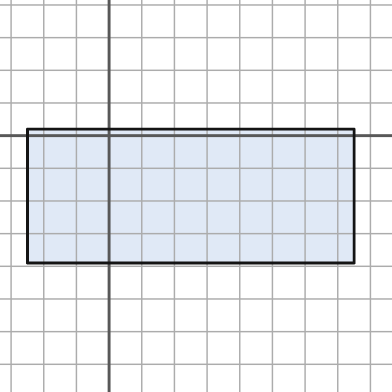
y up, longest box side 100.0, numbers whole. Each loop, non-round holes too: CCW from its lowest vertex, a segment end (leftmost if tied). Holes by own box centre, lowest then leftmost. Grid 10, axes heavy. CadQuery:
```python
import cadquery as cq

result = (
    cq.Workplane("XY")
    .moveTo(-25.0, -39.0)
    .lineTo(75.0, -39.0)
    .lineTo(75.0, 2.0)
    .lineTo(-25.0, 2.0)
    .close()
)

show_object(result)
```